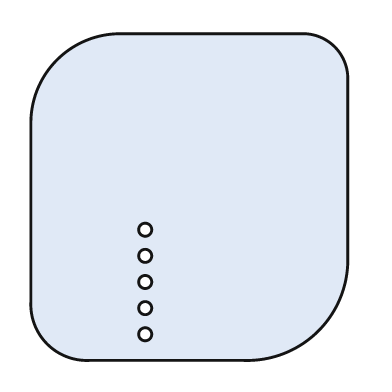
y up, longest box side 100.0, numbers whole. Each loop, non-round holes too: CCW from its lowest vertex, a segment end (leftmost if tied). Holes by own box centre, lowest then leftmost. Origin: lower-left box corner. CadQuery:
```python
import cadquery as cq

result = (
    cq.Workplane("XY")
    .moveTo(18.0, 0.0)
    .lineTo(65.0, 0.0)
    .threePointArc((88.0, 9.0), (97.0, 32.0))
    .lineTo(97.0, 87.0)
    .threePointArc((93.0, 96.0), (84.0, 100.0))
    .lineTo(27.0, 100.0)
    .threePointArc((8.0, 92.0), (0.0, 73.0))
    .lineTo(0.0, 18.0)
    .threePointArc((5.0, 5.0), (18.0, 0.0))
    .close()
    .moveTo(35.0, 8.0)
    .circle(2.0)
    .moveTo(35.0, 16.0)
    .circle(2.0)
    .moveTo(35.0, 24.0)
    .circle(2.0)
    .moveTo(35.0, 32.0)
    .circle(2.0)
    .moveTo(35.0, 40.0)
    .circle(2.0)
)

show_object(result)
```